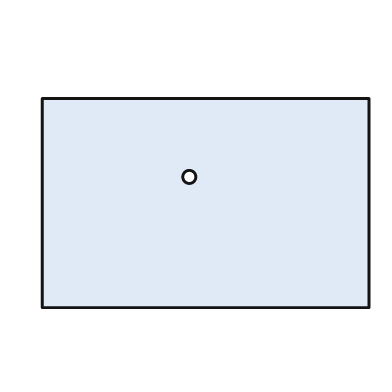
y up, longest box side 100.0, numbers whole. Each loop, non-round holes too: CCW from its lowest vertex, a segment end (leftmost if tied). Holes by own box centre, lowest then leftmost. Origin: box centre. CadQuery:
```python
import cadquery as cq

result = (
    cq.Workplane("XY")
    .moveTo(-50.0, -32.0)
    .lineTo(50.0, -32.0)
    .lineTo(50.0, 32.0)
    .lineTo(-50.0, 32.0)
    .close()
    .moveTo(-5.0, 8.0)
    .circle(2.0)
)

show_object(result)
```